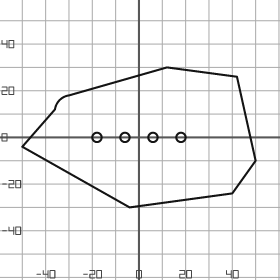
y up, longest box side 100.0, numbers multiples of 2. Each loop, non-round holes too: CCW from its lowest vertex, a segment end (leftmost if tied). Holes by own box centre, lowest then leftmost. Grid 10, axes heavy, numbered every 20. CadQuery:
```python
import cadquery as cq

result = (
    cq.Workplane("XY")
    .moveTo(-4.0, -30.0)
    .lineTo(40.0, -24.0)
    .lineTo(50.0, -10.0)
    .lineTo(42.0, 26.0)
    .lineTo(12.0, 30.0)
    .lineTo(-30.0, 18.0)
    .threePointArc((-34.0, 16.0), (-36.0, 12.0))
    .lineTo(-50.0, -4.0)
    .close()
    .moveTo(-18.0, 0.0)
    .circle(2.0)
    .moveTo(-6.0, 0.0)
    .circle(2.0)
    .moveTo(6.0, 0.0)
    .circle(2.0)
    .moveTo(18.0, 0.0)
    .circle(2.0)
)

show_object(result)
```